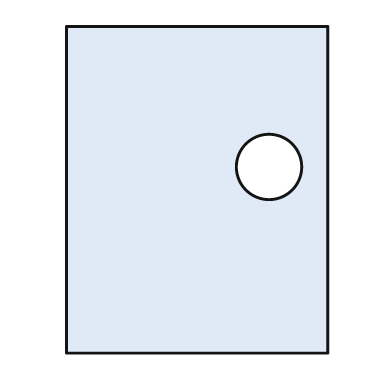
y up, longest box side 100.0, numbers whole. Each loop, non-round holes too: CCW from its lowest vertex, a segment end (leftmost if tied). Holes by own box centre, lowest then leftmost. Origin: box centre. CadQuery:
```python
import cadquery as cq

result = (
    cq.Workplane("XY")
    .moveTo(-40.0, -50.0)
    .lineTo(40.0, -50.0)
    .lineTo(40.0, 50.0)
    .lineTo(-40.0, 50.0)
    .close()
    .moveTo(22.0, 7.0)
    .circle(10.0)
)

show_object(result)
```